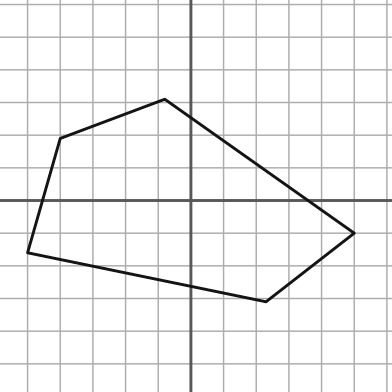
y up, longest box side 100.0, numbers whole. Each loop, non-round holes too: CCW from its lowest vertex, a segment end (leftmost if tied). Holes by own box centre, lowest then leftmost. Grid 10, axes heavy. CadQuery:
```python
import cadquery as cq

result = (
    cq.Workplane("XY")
    .moveTo(23.0, -31.0)
    .lineTo(50.0, -10.0)
    .lineTo(-8.0, 31.0)
    .lineTo(-40.0, 19.0)
    .lineTo(-50.0, -16.0)
    .close()
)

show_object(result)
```